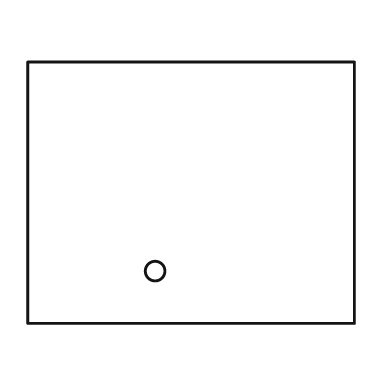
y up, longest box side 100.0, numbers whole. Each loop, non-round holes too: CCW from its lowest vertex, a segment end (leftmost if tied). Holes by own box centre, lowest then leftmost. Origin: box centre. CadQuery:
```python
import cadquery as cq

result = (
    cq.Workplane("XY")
    .moveTo(-50.0, -40.0)
    .lineTo(50.0, -40.0)
    .lineTo(50.0, 40.0)
    .lineTo(-50.0, 40.0)
    .close()
    .moveTo(-11.0, -24.0)
    .circle(3.0)
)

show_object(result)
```